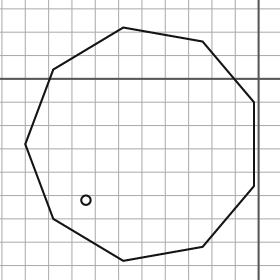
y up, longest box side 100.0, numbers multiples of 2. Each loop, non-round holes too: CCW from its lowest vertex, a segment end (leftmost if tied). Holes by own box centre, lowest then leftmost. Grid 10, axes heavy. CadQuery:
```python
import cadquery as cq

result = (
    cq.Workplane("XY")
    .moveTo(-58.0, -78.0)
    .lineTo(-24.0, -72.0)
    .lineTo(-2.0, -46.0)
    .lineTo(-2.0, -10.0)
    .lineTo(-24.0, 16.0)
    .lineTo(-58.0, 22.0)
    .lineTo(-88.0, 4.0)
    .lineTo(-100.0, -28.0)
    .lineTo(-88.0, -60.0)
    .close()
    .moveTo(-74.0, -52.0)
    .circle(2.0)
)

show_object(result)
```